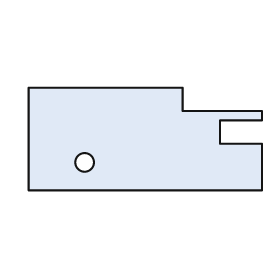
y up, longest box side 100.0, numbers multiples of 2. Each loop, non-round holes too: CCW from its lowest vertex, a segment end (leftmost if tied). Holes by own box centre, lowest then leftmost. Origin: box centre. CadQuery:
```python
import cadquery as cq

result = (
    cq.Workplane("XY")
    .moveTo(-50.0, -22.0)
    .lineTo(50.0, -22.0)
    .lineTo(50.0, -2.0)
    .lineTo(32.0, -2.0)
    .lineTo(32.0, 8.0)
    .lineTo(50.0, 8.0)
    .lineTo(50.0, 12.0)
    .lineTo(16.0, 12.0)
    .lineTo(16.0, 22.0)
    .lineTo(-50.0, 22.0)
    .close()
    .moveTo(-26.0, -10.0)
    .circle(4.0)
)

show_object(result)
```